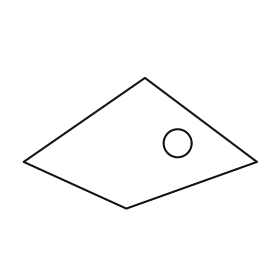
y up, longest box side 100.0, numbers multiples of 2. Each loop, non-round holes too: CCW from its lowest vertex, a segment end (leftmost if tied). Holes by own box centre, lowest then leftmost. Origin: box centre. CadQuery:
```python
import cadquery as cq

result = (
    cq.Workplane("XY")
    .moveTo(-6.0, -28.0)
    .lineTo(50.0, -8.0)
    .lineTo(2.0, 28.0)
    .lineTo(-50.0, -8.0)
    .close()
    .moveTo(16.0, 0.0)
    .circle(6.0)
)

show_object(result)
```